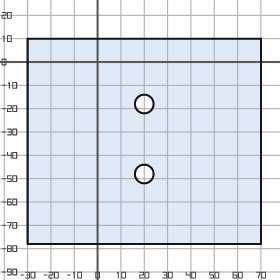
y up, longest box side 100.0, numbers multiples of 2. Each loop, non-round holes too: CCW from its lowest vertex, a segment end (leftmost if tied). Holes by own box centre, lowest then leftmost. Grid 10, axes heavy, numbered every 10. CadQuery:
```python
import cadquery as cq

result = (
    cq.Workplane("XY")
    .moveTo(-30.0, -78.0)
    .lineTo(70.0, -78.0)
    .lineTo(70.0, 10.0)
    .lineTo(-30.0, 10.0)
    .close()
    .moveTo(20.0, -48.0)
    .circle(4.0)
    .moveTo(20.0, -18.0)
    .circle(4.0)
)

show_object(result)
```